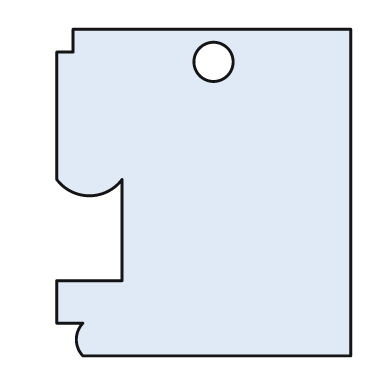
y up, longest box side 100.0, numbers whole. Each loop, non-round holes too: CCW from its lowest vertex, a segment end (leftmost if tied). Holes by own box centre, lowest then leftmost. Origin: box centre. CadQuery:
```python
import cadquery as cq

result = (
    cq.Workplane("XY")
    .moveTo(-37.0, -50.0)
    .lineTo(45.0, -50.0)
    .lineTo(45.0, 50.0)
    .lineTo(-40.0, 50.0)
    .lineTo(-40.0, 43.0)
    .lineTo(-45.0, 43.0)
    .lineTo(-45.0, 4.0)
    .threePointArc((-35.0, -1.0), (-25.0, 4.0))
    .lineTo(-25.0, -27.0)
    .lineTo(-45.0, -27.0)
    .lineTo(-45.0, -40.0)
    .lineTo(-37.0, -40.0)
    .threePointArc((-39.0, -45.0), (-37.0, -50.0))
    .close()
    .moveTo(3.0, 40.0)
    .circle(6.0)
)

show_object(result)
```